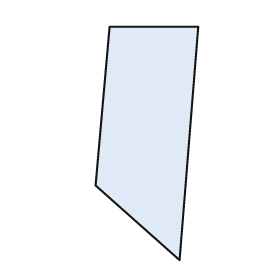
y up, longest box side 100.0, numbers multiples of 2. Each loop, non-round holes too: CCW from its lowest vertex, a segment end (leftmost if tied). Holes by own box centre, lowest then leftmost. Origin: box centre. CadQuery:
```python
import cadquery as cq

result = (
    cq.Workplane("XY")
    .moveTo(14.0, -50.0)
    .lineTo(22.0, 50.0)
    .lineTo(-16.0, 50.0)
    .lineTo(-22.0, -18.0)
    .close()
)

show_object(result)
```